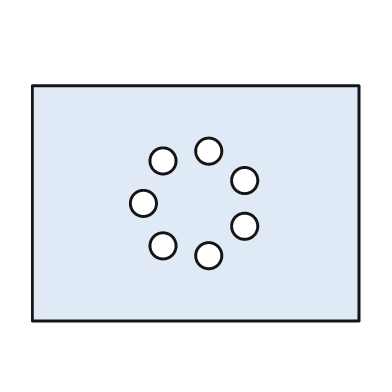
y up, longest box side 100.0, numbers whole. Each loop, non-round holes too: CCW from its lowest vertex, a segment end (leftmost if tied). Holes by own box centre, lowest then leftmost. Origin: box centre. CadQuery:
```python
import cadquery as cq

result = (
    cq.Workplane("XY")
    .moveTo(-50.0, -36.0)
    .lineTo(50.0, -36.0)
    .lineTo(50.0, 36.0)
    .lineTo(-50.0, 36.0)
    .close()
    .moveTo(4.0, -16.0)
    .circle(4.0)
    .moveTo(-10.0, -13.0)
    .circle(4.0)
    .moveTo(15.0, -7.0)
    .circle(4.0)
    .moveTo(-16.0, 0.0)
    .circle(4.0)
    .moveTo(15.0, 7.0)
    .circle(4.0)
    .moveTo(-10.0, 13.0)
    .circle(4.0)
    .moveTo(4.0, 16.0)
    .circle(4.0)
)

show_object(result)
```